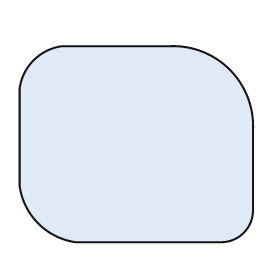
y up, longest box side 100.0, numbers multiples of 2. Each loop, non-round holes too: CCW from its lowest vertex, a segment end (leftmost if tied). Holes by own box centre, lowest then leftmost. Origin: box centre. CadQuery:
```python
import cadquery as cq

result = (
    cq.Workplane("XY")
    .moveTo(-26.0, -42.0)
    .lineTo(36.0, -42.0)
    .threePointArc((46.0, -38.0), (50.0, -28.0))
    .lineTo(50.0, 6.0)
    .threePointArc((40.0, 32.0), (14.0, 42.0))
    .lineTo(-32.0, 42.0)
    .threePointArc((-44.0, 36.0), (-50.0, 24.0))
    .lineTo(-50.0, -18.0)
    .threePointArc((-42.0, -34.0), (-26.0, -42.0))
    .close()
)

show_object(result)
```